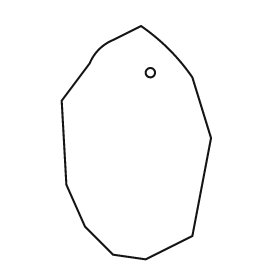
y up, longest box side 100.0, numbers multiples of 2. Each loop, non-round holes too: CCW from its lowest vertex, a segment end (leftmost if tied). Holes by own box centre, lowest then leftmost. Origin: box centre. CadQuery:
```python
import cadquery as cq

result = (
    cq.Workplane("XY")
    .moveTo(4.0, -50.0)
    .lineTo(24.0, -40.0)
    .lineTo(32.0, 2.0)
    .lineTo(24.0, 28.0)
    .threePointArc((14.0, 40.0), (2.0, 50.0))
    .lineTo(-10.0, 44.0)
    .threePointArc((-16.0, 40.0), (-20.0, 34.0))
    .lineTo(-32.0, 18.0)
    .lineTo(-30.0, -18.0)
    .lineTo(-22.0, -36.0)
    .lineTo(-10.0, -48.0)
    .close()
    .moveTo(6.0, 30.0)
    .circle(2.0)
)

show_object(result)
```